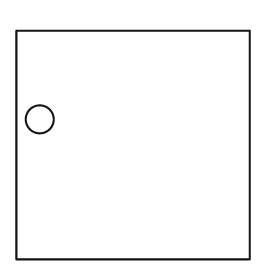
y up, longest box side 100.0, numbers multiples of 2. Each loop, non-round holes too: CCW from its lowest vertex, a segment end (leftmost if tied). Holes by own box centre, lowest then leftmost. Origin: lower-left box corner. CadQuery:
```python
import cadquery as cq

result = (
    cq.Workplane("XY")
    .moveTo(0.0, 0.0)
    .lineTo(100.0, 0.0)
    .lineTo(100.0, 98.0)
    .lineTo(0.0, 98.0)
    .close()
    .moveTo(10.0, 60.0)
    .circle(6.0)
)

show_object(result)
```